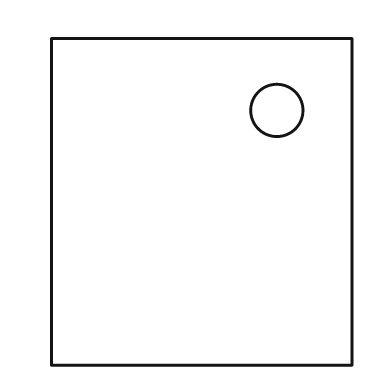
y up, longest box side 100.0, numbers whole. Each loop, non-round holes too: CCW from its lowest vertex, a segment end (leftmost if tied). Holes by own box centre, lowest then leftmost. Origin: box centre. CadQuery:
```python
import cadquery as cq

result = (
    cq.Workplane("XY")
    .moveTo(-46.0, -50.0)
    .lineTo(46.0, -50.0)
    .lineTo(46.0, 50.0)
    .lineTo(-46.0, 50.0)
    .close()
    .moveTo(23.0, 28.0)
    .circle(8.0)
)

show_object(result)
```